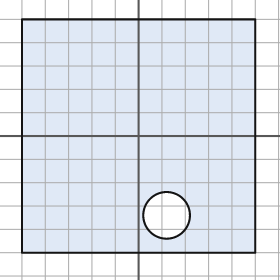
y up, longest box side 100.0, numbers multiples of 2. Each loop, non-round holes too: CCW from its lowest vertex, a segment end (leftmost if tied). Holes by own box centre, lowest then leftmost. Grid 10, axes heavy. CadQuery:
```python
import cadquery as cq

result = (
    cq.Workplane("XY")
    .moveTo(-50.0, -50.0)
    .lineTo(50.0, -50.0)
    .lineTo(50.0, 50.0)
    .lineTo(-50.0, 50.0)
    .close()
    .moveTo(12.0, -34.0)
    .circle(10.0)
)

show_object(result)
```